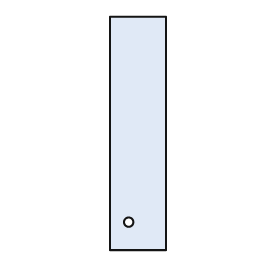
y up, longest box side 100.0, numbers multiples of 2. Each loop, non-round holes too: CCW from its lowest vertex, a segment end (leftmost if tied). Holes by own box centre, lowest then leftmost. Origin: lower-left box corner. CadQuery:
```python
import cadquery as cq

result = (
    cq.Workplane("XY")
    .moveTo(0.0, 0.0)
    .lineTo(24.0, 0.0)
    .lineTo(24.0, 100.0)
    .lineTo(0.0, 100.0)
    .close()
    .moveTo(8.0, 12.0)
    .circle(2.0)
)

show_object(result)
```